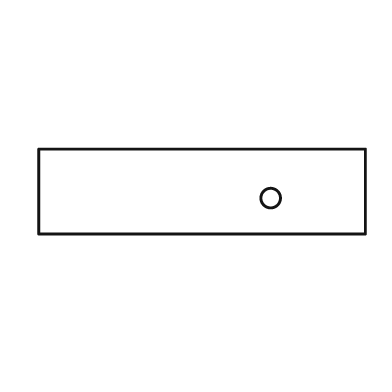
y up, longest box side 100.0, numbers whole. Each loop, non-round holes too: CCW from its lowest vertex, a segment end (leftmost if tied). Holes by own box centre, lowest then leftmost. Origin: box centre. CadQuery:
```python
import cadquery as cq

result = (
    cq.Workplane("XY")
    .moveTo(-50.0, -13.0)
    .lineTo(50.0, -13.0)
    .lineTo(50.0, 13.0)
    .lineTo(-50.0, 13.0)
    .close()
    .moveTo(21.0, -2.0)
    .circle(3.0)
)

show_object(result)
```